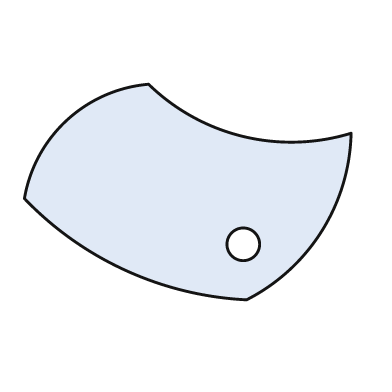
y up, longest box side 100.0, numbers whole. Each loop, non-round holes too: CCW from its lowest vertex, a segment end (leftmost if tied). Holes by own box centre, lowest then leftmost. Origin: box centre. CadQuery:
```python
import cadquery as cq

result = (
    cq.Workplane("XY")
    .moveTo(18.0, -33.0)
    .threePointArc((41.0, -12.0), (50.0, 18.0))
    .threePointArc((17.0, 17.0), (-12.0, 33.0))
    .threePointArc((-37.0, 22.0), (-50.0, -2.0))
    .threePointArc((-19.0, -24.0), (18.0, -33.0))
    .close()
    .moveTo(17.0, -16.0)
    .circle(5.0)
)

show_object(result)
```